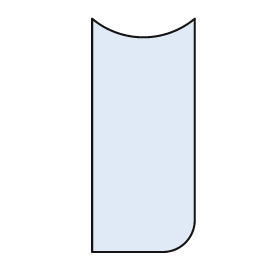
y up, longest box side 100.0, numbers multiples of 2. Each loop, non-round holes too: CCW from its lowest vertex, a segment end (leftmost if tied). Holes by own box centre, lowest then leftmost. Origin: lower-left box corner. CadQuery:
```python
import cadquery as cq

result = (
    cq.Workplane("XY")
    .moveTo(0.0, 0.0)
    .lineTo(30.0, 0.0)
    .threePointArc((40.0, 4.0), (44.0, 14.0))
    .lineTo(44.0, 100.0)
    .threePointArc((22.0, 92.0), (0.0, 100.0))
    .close()
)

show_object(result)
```